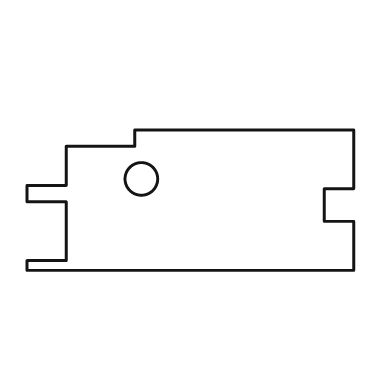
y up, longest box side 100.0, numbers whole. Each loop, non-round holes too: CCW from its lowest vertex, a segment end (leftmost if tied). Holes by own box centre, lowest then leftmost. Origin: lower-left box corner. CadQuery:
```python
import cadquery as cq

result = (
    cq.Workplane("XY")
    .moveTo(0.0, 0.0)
    .lineTo(100.0, 0.0)
    .lineTo(100.0, 15.0)
    .lineTo(91.0, 15.0)
    .lineTo(91.0, 25.0)
    .lineTo(100.0, 25.0)
    .lineTo(100.0, 43.0)
    .lineTo(33.0, 43.0)
    .lineTo(33.0, 38.0)
    .lineTo(12.0, 38.0)
    .lineTo(12.0, 26.0)
    .lineTo(0.0, 26.0)
    .lineTo(0.0, 21.0)
    .lineTo(12.0, 21.0)
    .lineTo(12.0, 3.0)
    .lineTo(0.0, 3.0)
    .close()
    .moveTo(35.0, 28.0)
    .circle(5.0)
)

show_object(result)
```